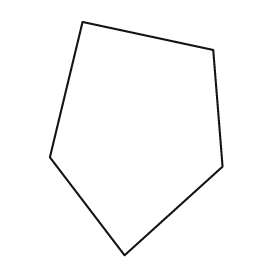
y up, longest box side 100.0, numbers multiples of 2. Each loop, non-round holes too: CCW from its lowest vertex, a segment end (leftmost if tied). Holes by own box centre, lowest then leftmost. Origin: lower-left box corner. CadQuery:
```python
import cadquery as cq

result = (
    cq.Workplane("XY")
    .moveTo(32.0, 0.0)
    .lineTo(74.0, 38.0)
    .lineTo(70.0, 88.0)
    .lineTo(14.0, 100.0)
    .lineTo(0.0, 42.0)
    .close()
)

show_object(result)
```